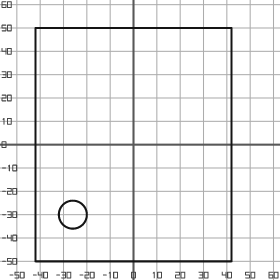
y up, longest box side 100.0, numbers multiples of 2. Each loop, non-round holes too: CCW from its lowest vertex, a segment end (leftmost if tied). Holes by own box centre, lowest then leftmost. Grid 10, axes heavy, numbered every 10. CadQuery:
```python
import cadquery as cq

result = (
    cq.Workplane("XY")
    .moveTo(-42.0, -50.0)
    .lineTo(42.0, -50.0)
    .lineTo(42.0, 50.0)
    .lineTo(-42.0, 50.0)
    .close()
    .moveTo(-26.0, -30.0)
    .circle(6.0)
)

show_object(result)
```